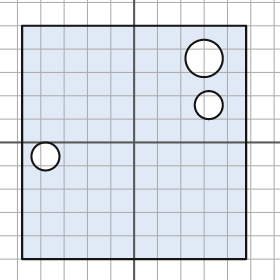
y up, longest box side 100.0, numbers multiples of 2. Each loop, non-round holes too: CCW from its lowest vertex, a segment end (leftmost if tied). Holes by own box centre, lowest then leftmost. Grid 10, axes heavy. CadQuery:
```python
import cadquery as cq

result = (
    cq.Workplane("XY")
    .moveTo(-48.0, -50.0)
    .lineTo(48.0, -50.0)
    .lineTo(48.0, 50.0)
    .lineTo(-48.0, 50.0)
    .close()
    .moveTo(-38.0, -6.0)
    .circle(6.0)
    .moveTo(32.0, 16.0)
    .circle(6.0)
    .moveTo(30.0, 36.0)
    .circle(8.0)
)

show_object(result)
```